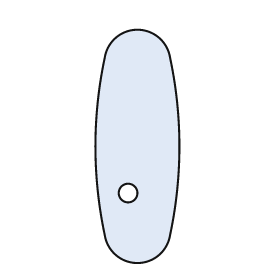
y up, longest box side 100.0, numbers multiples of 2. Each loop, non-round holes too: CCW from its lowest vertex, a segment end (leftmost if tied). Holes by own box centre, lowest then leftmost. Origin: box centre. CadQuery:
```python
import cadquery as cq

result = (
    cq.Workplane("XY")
    .moveTo(-14.0, -38.0)
    .threePointArc((0.0, -50.0), (14.0, -38.0))
    .threePointArc((18.0, 0.0), (14.0, 38.0))
    .threePointArc((0.0, 50.0), (-14.0, 38.0))
    .threePointArc((-18.0, 0.0), (-14.0, -38.0))
    .close()
    .moveTo(-4.0, -20.0)
    .circle(4.0)
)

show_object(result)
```